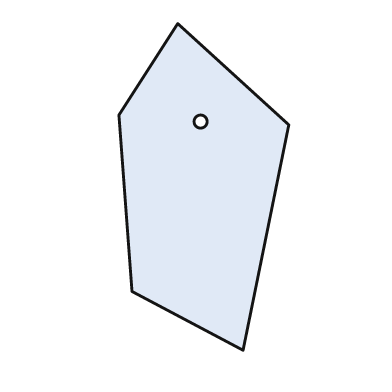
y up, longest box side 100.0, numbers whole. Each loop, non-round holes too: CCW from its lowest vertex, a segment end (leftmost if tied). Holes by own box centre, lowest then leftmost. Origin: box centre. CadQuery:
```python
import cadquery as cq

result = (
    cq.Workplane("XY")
    .moveTo(12.0, -50.0)
    .lineTo(26.0, 19.0)
    .lineTo(-8.0, 50.0)
    .lineTo(-26.0, 22.0)
    .lineTo(-22.0, -32.0)
    .close()
    .moveTo(-1.0, 20.0)
    .circle(2.0)
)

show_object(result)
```